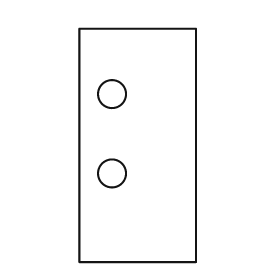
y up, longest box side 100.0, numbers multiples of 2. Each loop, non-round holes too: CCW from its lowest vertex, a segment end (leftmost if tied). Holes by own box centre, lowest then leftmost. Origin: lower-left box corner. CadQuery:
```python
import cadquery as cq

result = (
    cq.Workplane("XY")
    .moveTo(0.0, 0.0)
    .lineTo(50.0, 0.0)
    .lineTo(50.0, 100.0)
    .lineTo(0.0, 100.0)
    .close()
    .moveTo(14.0, 38.0)
    .circle(6.0)
    .moveTo(14.0, 72.0)
    .circle(6.0)
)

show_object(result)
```